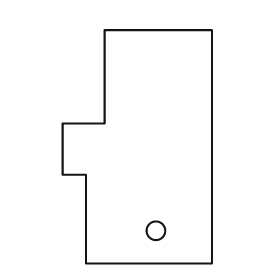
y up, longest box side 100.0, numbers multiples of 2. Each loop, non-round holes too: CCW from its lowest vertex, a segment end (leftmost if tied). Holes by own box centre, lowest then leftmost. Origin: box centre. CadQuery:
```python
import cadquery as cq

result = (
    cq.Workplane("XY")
    .moveTo(-22.0, -50.0)
    .lineTo(32.0, -50.0)
    .lineTo(32.0, 50.0)
    .lineTo(-14.0, 50.0)
    .lineTo(-14.0, 10.0)
    .lineTo(-32.0, 10.0)
    .lineTo(-32.0, -12.0)
    .lineTo(-22.0, -12.0)
    .close()
    .moveTo(8.0, -36.0)
    .circle(4.0)
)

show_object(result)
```